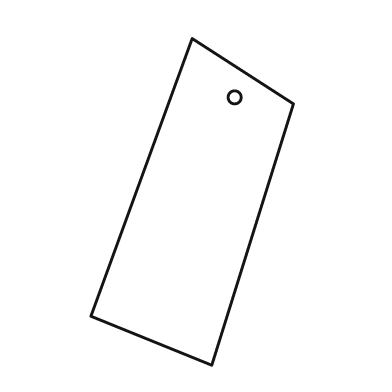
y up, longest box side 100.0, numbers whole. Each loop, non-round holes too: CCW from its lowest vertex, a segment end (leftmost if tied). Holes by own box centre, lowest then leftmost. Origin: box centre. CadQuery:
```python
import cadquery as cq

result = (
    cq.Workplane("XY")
    .moveTo(6.0, -50.0)
    .lineTo(31.0, 30.0)
    .lineTo(0.0, 50.0)
    .lineTo(-31.0, -35.0)
    .close()
    .moveTo(13.0, 32.0)
    .circle(2.0)
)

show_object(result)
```